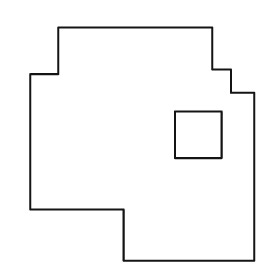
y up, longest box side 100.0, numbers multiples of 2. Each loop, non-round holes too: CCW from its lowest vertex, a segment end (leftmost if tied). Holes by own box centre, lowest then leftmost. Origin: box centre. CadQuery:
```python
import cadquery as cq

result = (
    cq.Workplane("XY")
    .moveTo(-8.0, -50.0)
    .lineTo(48.0, -50.0)
    .lineTo(48.0, 22.0)
    .lineTo(38.0, 22.0)
    .lineTo(38.0, 32.0)
    .lineTo(30.0, 32.0)
    .lineTo(30.0, 50.0)
    .lineTo(-36.0, 50.0)
    .lineTo(-36.0, 30.0)
    .lineTo(-48.0, 30.0)
    .lineTo(-48.0, -28.0)
    .lineTo(-8.0, -28.0)
    .close()
    .moveTo(14.0, -6.0)
    .lineTo(34.0, -6.0)
    .lineTo(34.0, 14.0)
    .lineTo(14.0, 14.0)
    .close()
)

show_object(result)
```